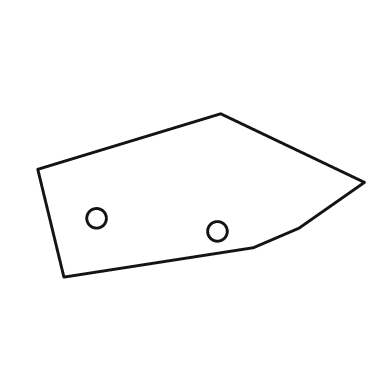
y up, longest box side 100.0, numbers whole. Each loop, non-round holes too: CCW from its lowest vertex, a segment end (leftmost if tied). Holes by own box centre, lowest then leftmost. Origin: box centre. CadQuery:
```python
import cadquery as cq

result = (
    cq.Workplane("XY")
    .moveTo(-42.0, -25.0)
    .lineTo(16.0, -16.0)
    .lineTo(30.0, -10.0)
    .lineTo(50.0, 4.0)
    .lineTo(6.0, 25.0)
    .lineTo(-50.0, 8.0)
    .close()
    .moveTo(5.0, -11.0)
    .circle(3.0)
    .moveTo(-32.0, -7.0)
    .circle(3.0)
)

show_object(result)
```